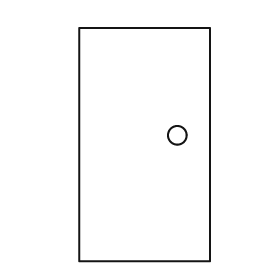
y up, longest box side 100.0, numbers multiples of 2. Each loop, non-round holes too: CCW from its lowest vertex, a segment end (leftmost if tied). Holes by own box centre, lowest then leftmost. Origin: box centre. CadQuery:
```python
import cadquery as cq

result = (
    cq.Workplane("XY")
    .moveTo(-28.0, -50.0)
    .lineTo(28.0, -50.0)
    .lineTo(28.0, 50.0)
    .lineTo(-28.0, 50.0)
    .close()
    .moveTo(14.0, 4.0)
    .circle(4.0)
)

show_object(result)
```